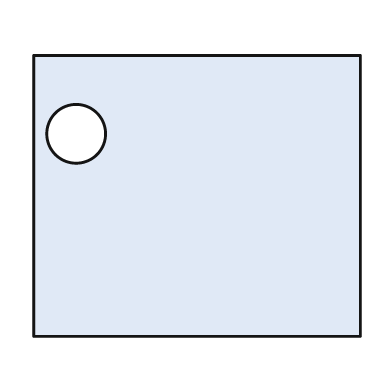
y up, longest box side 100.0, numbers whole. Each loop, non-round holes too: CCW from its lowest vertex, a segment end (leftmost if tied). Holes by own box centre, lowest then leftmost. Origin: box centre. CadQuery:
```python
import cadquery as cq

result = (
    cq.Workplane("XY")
    .moveTo(-50.0, -43.0)
    .lineTo(50.0, -43.0)
    .lineTo(50.0, 43.0)
    .lineTo(-50.0, 43.0)
    .close()
    .moveTo(-37.0, 19.0)
    .circle(9.0)
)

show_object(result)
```